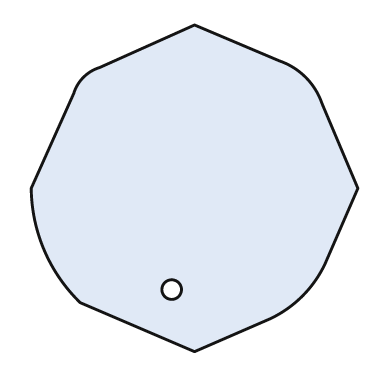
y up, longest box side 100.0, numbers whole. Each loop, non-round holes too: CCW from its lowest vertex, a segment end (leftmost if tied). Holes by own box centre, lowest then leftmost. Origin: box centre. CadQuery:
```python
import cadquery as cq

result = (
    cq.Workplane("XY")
    .moveTo(0.0, -50.0)
    .lineTo(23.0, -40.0)
    .threePointArc((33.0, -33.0), (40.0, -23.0))
    .lineTo(50.0, 0.0)
    .lineTo(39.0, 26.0)
    .threePointArc((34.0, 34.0), (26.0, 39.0))
    .lineTo(0.0, 50.0)
    .lineTo(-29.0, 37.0)
    .threePointArc((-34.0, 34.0), (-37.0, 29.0))
    .lineTo(-50.0, 0.0)
    .threePointArc((-46.0, -19.0), (-35.0, -35.0))
    .close()
    .moveTo(-7.0, -31.0)
    .circle(3.0)
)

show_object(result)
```